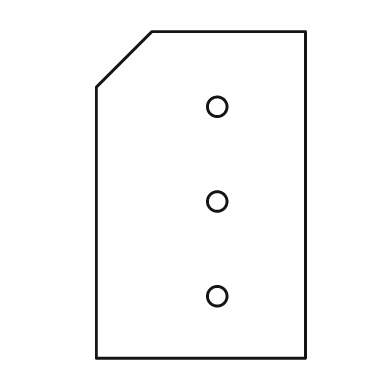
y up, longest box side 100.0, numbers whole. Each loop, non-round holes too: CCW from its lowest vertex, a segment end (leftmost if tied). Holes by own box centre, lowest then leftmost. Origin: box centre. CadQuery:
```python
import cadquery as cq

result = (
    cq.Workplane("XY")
    .moveTo(-32.0, -50.0)
    .lineTo(32.0, -50.0)
    .lineTo(32.0, 50.0)
    .lineTo(-15.0, 50.0)
    .lineTo(-32.0, 33.0)
    .close()
    .moveTo(5.0, -31.0)
    .circle(3.0)
    .moveTo(5.0, -2.0)
    .circle(3.0)
    .moveTo(5.0, 27.0)
    .circle(3.0)
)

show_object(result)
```